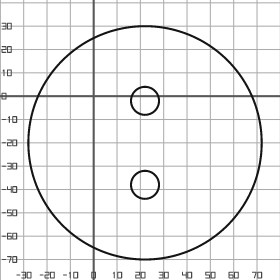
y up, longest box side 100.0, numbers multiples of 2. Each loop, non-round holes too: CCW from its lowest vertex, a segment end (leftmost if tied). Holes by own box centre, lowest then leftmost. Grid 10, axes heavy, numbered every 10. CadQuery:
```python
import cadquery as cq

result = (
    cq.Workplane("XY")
    .moveTo(22.0, -20.0)
    .circle(50.0)
    .moveTo(22.0, -38.0)
    .circle(6.0)
    .moveTo(22.0, -2.0)
    .circle(6.0)
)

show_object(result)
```